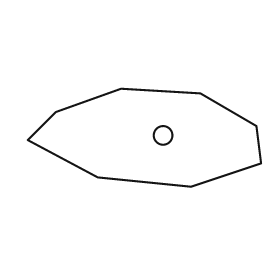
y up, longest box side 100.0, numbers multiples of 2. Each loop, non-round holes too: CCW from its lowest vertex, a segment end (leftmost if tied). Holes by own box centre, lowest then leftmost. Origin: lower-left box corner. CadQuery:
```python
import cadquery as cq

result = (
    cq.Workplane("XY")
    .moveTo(70.0, 0.0)
    .lineTo(100.0, 10.0)
    .lineTo(98.0, 26.0)
    .lineTo(74.0, 40.0)
    .lineTo(40.0, 42.0)
    .lineTo(12.0, 32.0)
    .lineTo(0.0, 20.0)
    .lineTo(30.0, 4.0)
    .close()
    .moveTo(58.0, 22.0)
    .circle(4.0)
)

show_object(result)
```